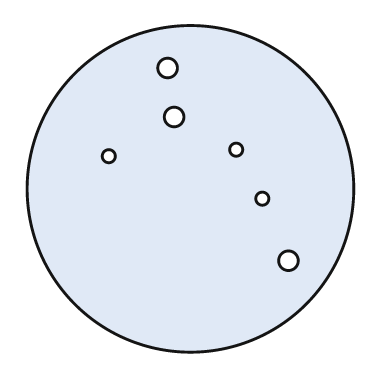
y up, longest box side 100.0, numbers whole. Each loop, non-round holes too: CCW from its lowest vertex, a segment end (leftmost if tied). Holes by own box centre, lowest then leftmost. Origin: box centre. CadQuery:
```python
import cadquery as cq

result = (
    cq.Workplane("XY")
    .moveTo(0.0, 0.0)
    .circle(50.0)
    .moveTo(30.0, -22.0)
    .circle(3.0)
    .moveTo(22.0, -3.0)
    .circle(2.0)
    .moveTo(-25.0, 10.0)
    .circle(2.0)
    .moveTo(14.0, 12.0)
    .circle(2.0)
    .moveTo(-5.0, 22.0)
    .circle(3.0)
    .moveTo(-7.0, 37.0)
    .circle(3.0)
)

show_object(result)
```